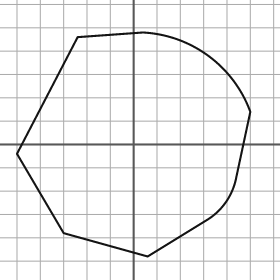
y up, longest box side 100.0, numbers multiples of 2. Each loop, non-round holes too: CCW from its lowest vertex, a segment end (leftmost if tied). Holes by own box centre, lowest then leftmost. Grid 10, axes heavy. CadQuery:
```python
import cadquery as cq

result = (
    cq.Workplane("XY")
    .moveTo(6.0, -48.0)
    .lineTo(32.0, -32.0)
    .threePointArc((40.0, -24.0), (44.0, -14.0))
    .lineTo(50.0, 14.0)
    .threePointArc((32.0, 38.0), (4.0, 48.0))
    .lineTo(-24.0, 46.0)
    .lineTo(-50.0, -4.0)
    .lineTo(-30.0, -38.0)
    .close()
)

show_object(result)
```